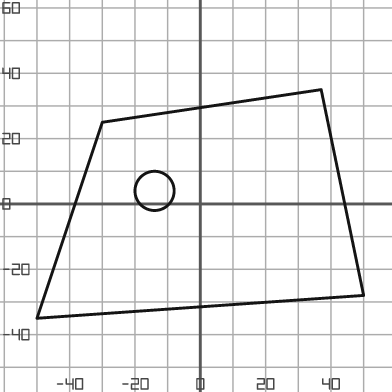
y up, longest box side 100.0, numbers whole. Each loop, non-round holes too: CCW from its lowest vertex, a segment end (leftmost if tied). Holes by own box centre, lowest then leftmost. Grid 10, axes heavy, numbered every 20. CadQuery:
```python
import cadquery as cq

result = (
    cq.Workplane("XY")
    .moveTo(-50.0, -35.0)
    .lineTo(50.0, -28.0)
    .lineTo(37.0, 35.0)
    .lineTo(-30.0, 25.0)
    .close()
    .moveTo(-14.0, 4.0)
    .circle(6.0)
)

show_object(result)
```